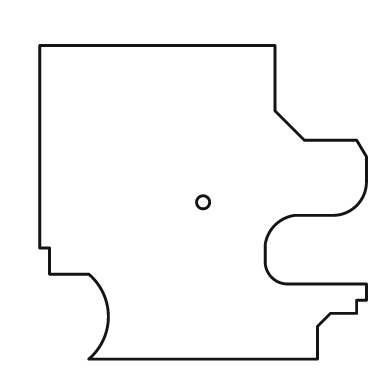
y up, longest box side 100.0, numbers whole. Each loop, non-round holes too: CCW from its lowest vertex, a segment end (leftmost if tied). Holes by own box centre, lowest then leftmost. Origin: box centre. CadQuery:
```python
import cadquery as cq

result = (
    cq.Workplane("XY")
    .moveTo(-35.0, -48.0)
    .lineTo(35.0, -48.0)
    .lineTo(35.0, -38.0)
    .lineTo(39.0, -34.0)
    .lineTo(47.0, -34.0)
    .lineTo(47.0, -30.0)
    .lineTo(50.0, -30.0)
    .lineTo(50.0, -25.0)
    .lineTo(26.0, -25.0)
    .threePointArc((21.0, -23.0), (19.0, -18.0))
    .lineTo(19.0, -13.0)
    .threePointArc((22.0, -7.0), (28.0, -4.0))
    .lineTo(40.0, -4.0)
    .threePointArc((47.0, -1.0), (50.0, 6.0))
    .lineTo(50.0, 14.0)
    .lineTo(47.0, 19.0)
    .lineTo(31.0, 19.0)
    .lineTo(22.0, 28.0)
    .lineTo(22.0, 48.0)
    .lineTo(-50.0, 48.0)
    .lineTo(-50.0, -14.0)
    .lineTo(-47.0, -14.0)
    .lineTo(-47.0, -22.0)
    .lineTo(-35.0, -22.0)
    .threePointArc((-29.0, -35.0), (-35.0, -48.0))
    .close()
    .moveTo(0.0, 0.0)
    .circle(2.0)
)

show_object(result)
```